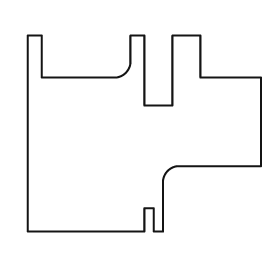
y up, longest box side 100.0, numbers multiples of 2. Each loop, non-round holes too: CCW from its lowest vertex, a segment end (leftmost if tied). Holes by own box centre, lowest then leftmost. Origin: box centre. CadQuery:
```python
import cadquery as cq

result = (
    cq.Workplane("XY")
    .moveTo(-50.0, -42.0)
    .lineTo(0.0, -42.0)
    .lineTo(0.0, -32.0)
    .lineTo(4.0, -32.0)
    .lineTo(4.0, -42.0)
    .lineTo(8.0, -42.0)
    .lineTo(8.0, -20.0)
    .threePointArc((10.0, -16.0), (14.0, -14.0))
    .lineTo(50.0, -14.0)
    .lineTo(50.0, 24.0)
    .lineTo(24.0, 24.0)
    .lineTo(24.0, 42.0)
    .lineTo(12.0, 42.0)
    .lineTo(12.0, 12.0)
    .lineTo(0.0, 12.0)
    .lineTo(0.0, 42.0)
    .lineTo(-6.0, 42.0)
    .lineTo(-6.0, 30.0)
    .threePointArc((-8.0, 26.0), (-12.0, 24.0))
    .lineTo(-44.0, 24.0)
    .lineTo(-44.0, 42.0)
    .lineTo(-50.0, 42.0)
    .close()
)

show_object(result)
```